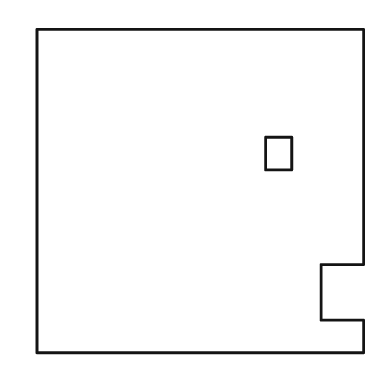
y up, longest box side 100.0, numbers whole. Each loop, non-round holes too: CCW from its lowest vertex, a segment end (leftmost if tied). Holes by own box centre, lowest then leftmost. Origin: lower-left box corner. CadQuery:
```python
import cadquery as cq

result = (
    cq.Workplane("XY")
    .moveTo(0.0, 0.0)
    .lineTo(100.0, 0.0)
    .lineTo(100.0, 10.0)
    .lineTo(87.0, 10.0)
    .lineTo(87.0, 27.0)
    .lineTo(100.0, 27.0)
    .lineTo(100.0, 99.0)
    .lineTo(0.0, 99.0)
    .close()
    .moveTo(70.0, 56.0)
    .lineTo(78.0, 56.0)
    .lineTo(78.0, 66.0)
    .lineTo(70.0, 66.0)
    .close()
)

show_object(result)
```